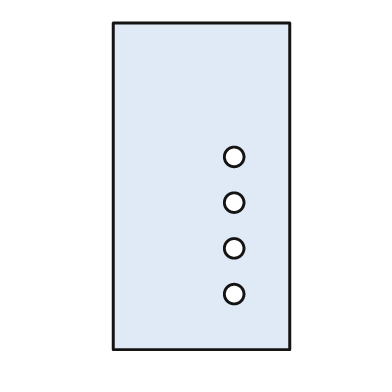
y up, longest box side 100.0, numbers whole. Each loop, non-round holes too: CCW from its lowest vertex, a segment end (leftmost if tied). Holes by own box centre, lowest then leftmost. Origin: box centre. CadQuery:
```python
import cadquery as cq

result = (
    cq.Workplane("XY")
    .moveTo(-27.0, -50.0)
    .lineTo(27.0, -50.0)
    .lineTo(27.0, 50.0)
    .lineTo(-27.0, 50.0)
    .close()
    .moveTo(10.0, -33.0)
    .circle(3.0)
    .moveTo(10.0, -19.0)
    .circle(3.0)
    .moveTo(10.0, -5.0)
    .circle(3.0)
    .moveTo(10.0, 9.0)
    .circle(3.0)
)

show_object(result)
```